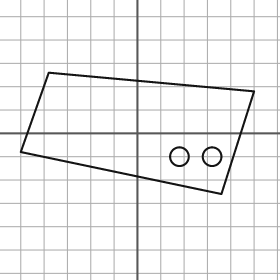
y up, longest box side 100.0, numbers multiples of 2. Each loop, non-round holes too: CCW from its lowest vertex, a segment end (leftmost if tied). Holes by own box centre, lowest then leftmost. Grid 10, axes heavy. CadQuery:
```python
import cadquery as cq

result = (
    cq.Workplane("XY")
    .moveTo(36.0, -26.0)
    .lineTo(50.0, 18.0)
    .lineTo(-38.0, 26.0)
    .lineTo(-50.0, -8.0)
    .close()
    .moveTo(18.0, -10.0)
    .circle(4.0)
    .moveTo(32.0, -10.0)
    .circle(4.0)
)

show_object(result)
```